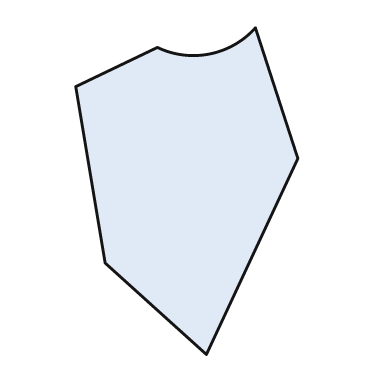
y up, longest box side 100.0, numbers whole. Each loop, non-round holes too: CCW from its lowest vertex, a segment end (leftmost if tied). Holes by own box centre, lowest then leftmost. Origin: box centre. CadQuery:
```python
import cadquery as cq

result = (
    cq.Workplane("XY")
    .moveTo(6.0, -50.0)
    .lineTo(34.0, 10.0)
    .lineTo(21.0, 50.0)
    .threePointArc((7.0, 42.0), (-9.0, 44.0))
    .lineTo(-34.0, 32.0)
    .lineTo(-25.0, -22.0)
    .close()
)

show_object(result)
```